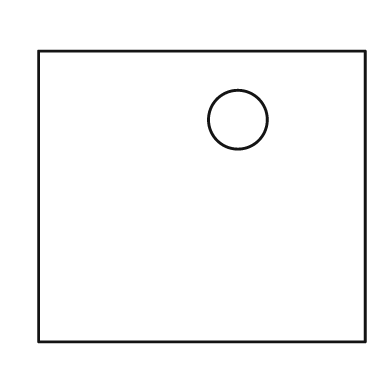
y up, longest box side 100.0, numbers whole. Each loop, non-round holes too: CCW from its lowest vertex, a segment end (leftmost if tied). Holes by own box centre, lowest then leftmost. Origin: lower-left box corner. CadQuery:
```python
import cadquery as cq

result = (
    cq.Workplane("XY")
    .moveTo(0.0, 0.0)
    .lineTo(100.0, 0.0)
    .lineTo(100.0, 89.0)
    .lineTo(0.0, 89.0)
    .close()
    .moveTo(61.0, 68.0)
    .circle(9.0)
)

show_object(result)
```